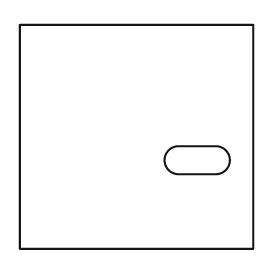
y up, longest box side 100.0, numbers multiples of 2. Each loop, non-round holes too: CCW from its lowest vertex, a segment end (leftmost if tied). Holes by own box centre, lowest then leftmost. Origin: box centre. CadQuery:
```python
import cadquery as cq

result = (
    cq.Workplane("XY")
    .moveTo(-50.0, -48.0)
    .lineTo(50.0, -48.0)
    .lineTo(50.0, 48.0)
    .lineTo(-50.0, 48.0)
    .close()
    .moveTo(18.0, -16.0)
    .lineTo(34.0, -16.0)
    .threePointArc((40.0, -10.0), (34.0, -4.0))
    .lineTo(18.0, -4.0)
    .threePointArc((12.0, -10.0), (18.0, -16.0))
    .close()
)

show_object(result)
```